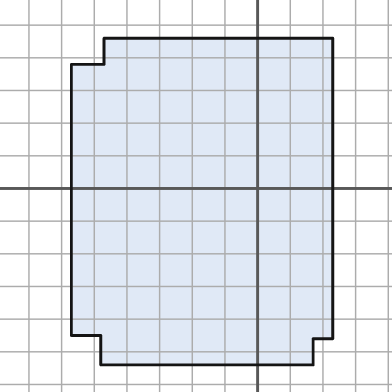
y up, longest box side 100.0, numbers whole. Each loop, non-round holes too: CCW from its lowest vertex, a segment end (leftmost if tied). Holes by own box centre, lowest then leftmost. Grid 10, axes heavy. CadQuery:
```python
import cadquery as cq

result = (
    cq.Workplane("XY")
    .moveTo(-48.0, -54.0)
    .lineTo(17.0, -54.0)
    .lineTo(17.0, -46.0)
    .lineTo(23.0, -46.0)
    .lineTo(23.0, 46.0)
    .lineTo(-47.0, 46.0)
    .lineTo(-47.0, 38.0)
    .lineTo(-57.0, 38.0)
    .lineTo(-57.0, -45.0)
    .lineTo(-48.0, -45.0)
    .close()
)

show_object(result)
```